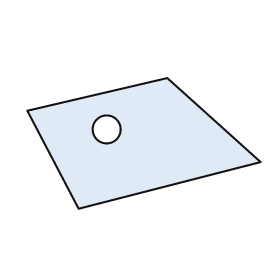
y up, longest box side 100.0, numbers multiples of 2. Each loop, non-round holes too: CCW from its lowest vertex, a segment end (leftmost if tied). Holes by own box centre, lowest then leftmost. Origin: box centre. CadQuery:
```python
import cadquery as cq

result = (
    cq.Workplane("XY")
    .moveTo(-28.0, -28.0)
    .lineTo(50.0, -8.0)
    .lineTo(10.0, 28.0)
    .lineTo(-50.0, 14.0)
    .close()
    .moveTo(-16.0, 6.0)
    .circle(6.0)
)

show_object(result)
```